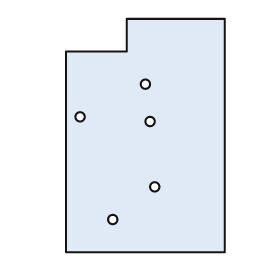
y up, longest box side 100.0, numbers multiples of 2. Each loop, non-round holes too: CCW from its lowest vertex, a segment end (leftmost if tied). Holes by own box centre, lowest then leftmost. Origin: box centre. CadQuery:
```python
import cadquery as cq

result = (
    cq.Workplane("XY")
    .moveTo(-34.0, -50.0)
    .lineTo(34.0, -50.0)
    .lineTo(34.0, 50.0)
    .lineTo(-8.0, 50.0)
    .lineTo(-8.0, 36.0)
    .lineTo(-34.0, 36.0)
    .close()
    .moveTo(-14.0, -36.0)
    .circle(2.0)
    .moveTo(4.0, -22.0)
    .circle(2.0)
    .moveTo(2.0, 6.0)
    .circle(2.0)
    .moveTo(-28.0, 8.0)
    .circle(2.0)
    .moveTo(0.0, 22.0)
    .circle(2.0)
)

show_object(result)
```